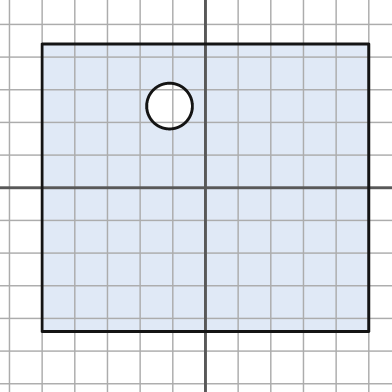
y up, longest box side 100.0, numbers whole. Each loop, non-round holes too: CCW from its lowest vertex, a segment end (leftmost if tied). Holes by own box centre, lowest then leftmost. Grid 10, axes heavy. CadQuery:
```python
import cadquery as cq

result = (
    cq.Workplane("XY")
    .moveTo(-50.0, -44.0)
    .lineTo(50.0, -44.0)
    .lineTo(50.0, 44.0)
    .lineTo(-50.0, 44.0)
    .close()
    .moveTo(-11.0, 25.0)
    .circle(7.0)
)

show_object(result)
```